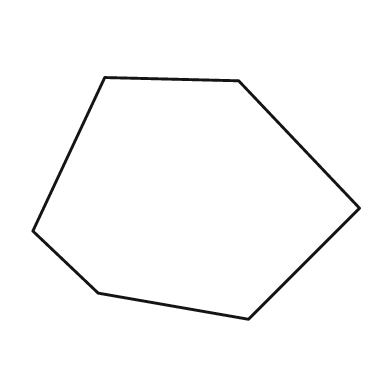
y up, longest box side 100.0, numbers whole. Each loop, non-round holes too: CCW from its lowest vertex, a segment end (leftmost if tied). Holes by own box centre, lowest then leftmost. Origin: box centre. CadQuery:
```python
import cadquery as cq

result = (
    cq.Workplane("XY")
    .moveTo(16.0, -37.0)
    .lineTo(50.0, -3.0)
    .lineTo(13.0, 36.0)
    .lineTo(-28.0, 37.0)
    .lineTo(-50.0, -10.0)
    .lineTo(-30.0, -29.0)
    .close()
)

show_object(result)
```